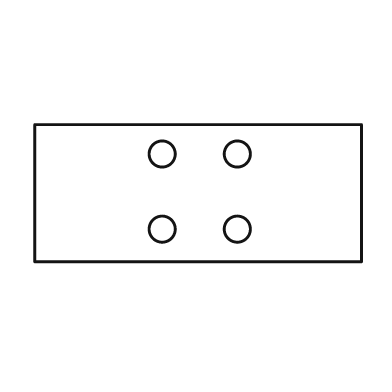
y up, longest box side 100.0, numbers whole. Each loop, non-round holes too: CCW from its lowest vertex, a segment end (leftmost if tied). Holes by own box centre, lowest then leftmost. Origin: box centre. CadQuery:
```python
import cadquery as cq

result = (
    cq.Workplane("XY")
    .moveTo(-50.0, -21.0)
    .lineTo(50.0, -21.0)
    .lineTo(50.0, 21.0)
    .lineTo(-50.0, 21.0)
    .close()
    .moveTo(-11.0, -11.0)
    .circle(4.0)
    .moveTo(12.0, -11.0)
    .circle(4.0)
    .moveTo(-11.0, 12.0)
    .circle(4.0)
    .moveTo(12.0, 12.0)
    .circle(4.0)
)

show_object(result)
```